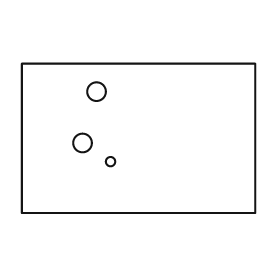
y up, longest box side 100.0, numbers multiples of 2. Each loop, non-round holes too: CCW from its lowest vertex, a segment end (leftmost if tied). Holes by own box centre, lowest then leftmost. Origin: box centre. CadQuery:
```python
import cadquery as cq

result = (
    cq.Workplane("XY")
    .moveTo(-50.0, -32.0)
    .lineTo(50.0, -32.0)
    .lineTo(50.0, 32.0)
    .lineTo(-50.0, 32.0)
    .close()
    .moveTo(-12.0, -10.0)
    .circle(2.0)
    .moveTo(-24.0, -2.0)
    .circle(4.0)
    .moveTo(-18.0, 20.0)
    .circle(4.0)
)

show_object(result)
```